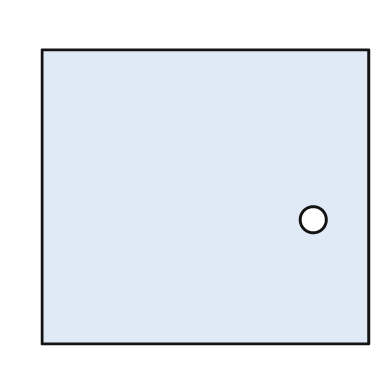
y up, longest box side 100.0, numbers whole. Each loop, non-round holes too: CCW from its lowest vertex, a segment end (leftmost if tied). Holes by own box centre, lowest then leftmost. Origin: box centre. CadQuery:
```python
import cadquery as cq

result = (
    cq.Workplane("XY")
    .moveTo(-50.0, -45.0)
    .lineTo(50.0, -45.0)
    .lineTo(50.0, 45.0)
    .lineTo(-50.0, 45.0)
    .close()
    .moveTo(33.0, -7.0)
    .circle(4.0)
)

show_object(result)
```